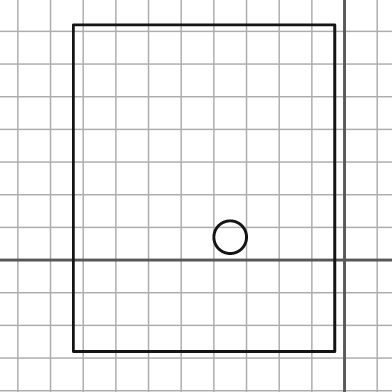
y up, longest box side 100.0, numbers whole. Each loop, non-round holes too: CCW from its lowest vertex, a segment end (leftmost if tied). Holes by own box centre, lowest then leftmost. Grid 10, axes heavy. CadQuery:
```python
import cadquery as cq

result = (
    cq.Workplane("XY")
    .moveTo(-83.0, -28.0)
    .lineTo(-3.0, -28.0)
    .lineTo(-3.0, 72.0)
    .lineTo(-83.0, 72.0)
    .close()
    .moveTo(-35.0, 7.0)
    .circle(5.0)
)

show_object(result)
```